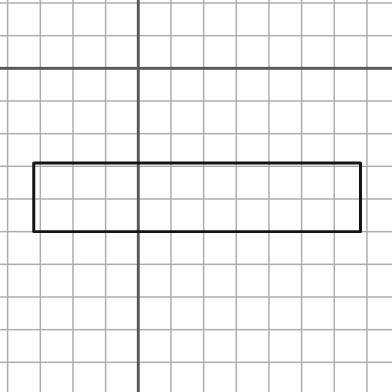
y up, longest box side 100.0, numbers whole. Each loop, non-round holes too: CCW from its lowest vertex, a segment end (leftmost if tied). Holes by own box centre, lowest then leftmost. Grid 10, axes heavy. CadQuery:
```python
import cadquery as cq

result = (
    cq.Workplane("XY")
    .moveTo(-32.0, -50.0)
    .lineTo(68.0, -50.0)
    .lineTo(68.0, -29.0)
    .lineTo(-32.0, -29.0)
    .close()
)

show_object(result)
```